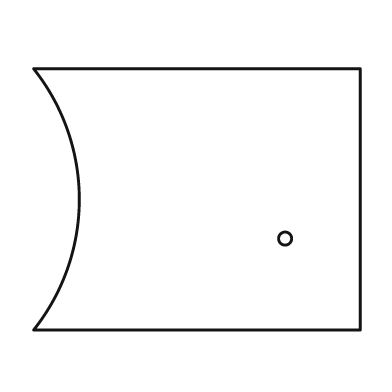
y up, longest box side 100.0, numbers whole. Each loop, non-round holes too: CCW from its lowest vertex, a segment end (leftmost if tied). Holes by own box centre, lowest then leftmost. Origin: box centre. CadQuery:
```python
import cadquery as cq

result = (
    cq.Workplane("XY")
    .moveTo(-50.0, -40.0)
    .lineTo(50.0, -40.0)
    .lineTo(50.0, 40.0)
    .lineTo(-50.0, 40.0)
    .threePointArc((-36.0, 0.0), (-50.0, -40.0))
    .close()
    .moveTo(27.0, -12.0)
    .circle(2.0)
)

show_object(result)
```